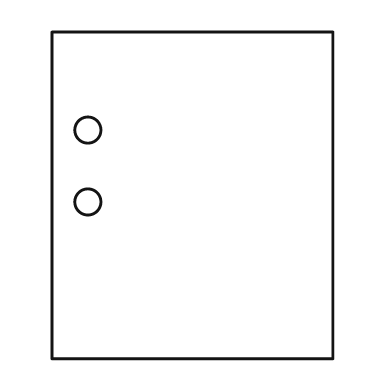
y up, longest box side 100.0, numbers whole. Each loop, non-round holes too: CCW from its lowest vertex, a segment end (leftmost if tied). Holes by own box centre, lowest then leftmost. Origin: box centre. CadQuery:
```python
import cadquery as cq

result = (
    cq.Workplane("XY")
    .moveTo(-43.0, -50.0)
    .lineTo(43.0, -50.0)
    .lineTo(43.0, 50.0)
    .lineTo(-43.0, 50.0)
    .close()
    .moveTo(-32.0, -2.0)
    .circle(4.0)
    .moveTo(-32.0, 20.0)
    .circle(4.0)
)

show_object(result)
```